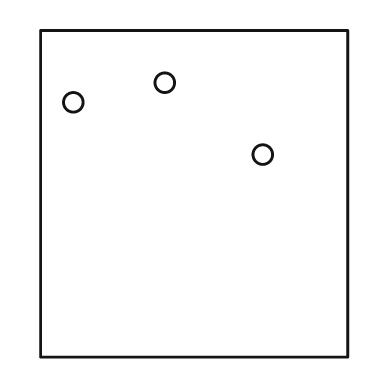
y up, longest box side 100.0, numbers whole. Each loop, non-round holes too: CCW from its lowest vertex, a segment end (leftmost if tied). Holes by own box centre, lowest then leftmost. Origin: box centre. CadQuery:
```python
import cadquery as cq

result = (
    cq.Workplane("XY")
    .moveTo(-47.0, -50.0)
    .lineTo(47.0, -50.0)
    .lineTo(47.0, 50.0)
    .lineTo(-47.0, 50.0)
    .close()
    .moveTo(21.0, 12.0)
    .circle(3.0)
    .moveTo(-37.0, 28.0)
    .circle(3.0)
    .moveTo(-9.0, 34.0)
    .circle(3.0)
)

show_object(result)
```